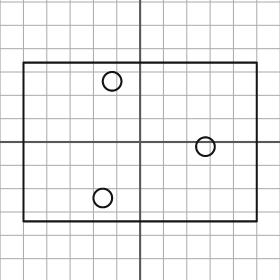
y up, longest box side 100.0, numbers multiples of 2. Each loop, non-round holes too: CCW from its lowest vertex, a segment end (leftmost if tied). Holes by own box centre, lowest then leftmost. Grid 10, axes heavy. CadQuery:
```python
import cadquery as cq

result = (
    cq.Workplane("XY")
    .moveTo(-50.0, -34.0)
    .lineTo(50.0, -34.0)
    .lineTo(50.0, 34.0)
    .lineTo(-50.0, 34.0)
    .close()
    .moveTo(-16.0, -24.0)
    .circle(4.0)
    .moveTo(28.0, -2.0)
    .circle(4.0)
    .moveTo(-12.0, 26.0)
    .circle(4.0)
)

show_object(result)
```